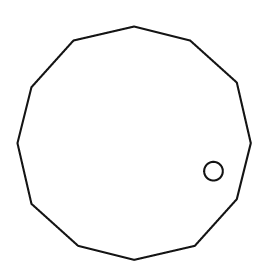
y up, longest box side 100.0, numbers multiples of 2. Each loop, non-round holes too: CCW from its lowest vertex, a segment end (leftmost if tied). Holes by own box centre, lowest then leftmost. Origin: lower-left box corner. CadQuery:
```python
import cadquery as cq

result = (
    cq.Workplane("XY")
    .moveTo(50.0, 0.0)
    .lineTo(76.0, 6.0)
    .lineTo(94.0, 26.0)
    .lineTo(100.0, 50.0)
    .lineTo(94.0, 76.0)
    .lineTo(74.0, 94.0)
    .lineTo(50.0, 100.0)
    .lineTo(24.0, 94.0)
    .lineTo(6.0, 74.0)
    .lineTo(0.0, 50.0)
    .lineTo(6.0, 24.0)
    .lineTo(26.0, 6.0)
    .close()
    .moveTo(84.0, 38.0)
    .circle(4.0)
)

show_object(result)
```